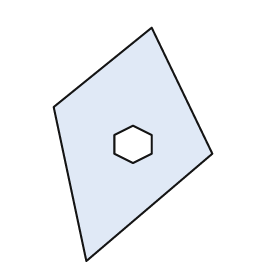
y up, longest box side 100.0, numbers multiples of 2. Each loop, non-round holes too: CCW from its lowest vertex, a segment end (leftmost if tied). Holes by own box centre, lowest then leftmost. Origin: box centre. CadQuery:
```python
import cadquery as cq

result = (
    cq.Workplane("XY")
    .moveTo(-20.0, -50.0)
    .lineTo(34.0, -4.0)
    .lineTo(8.0, 50.0)
    .lineTo(-34.0, 16.0)
    .close()
    .moveTo(0.0, -8.0)
    .lineTo(8.0, -4.0)
    .lineTo(8.0, 4.0)
    .lineTo(0.0, 8.0)
    .lineTo(-8.0, 4.0)
    .lineTo(-8.0, -4.0)
    .close()
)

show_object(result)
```